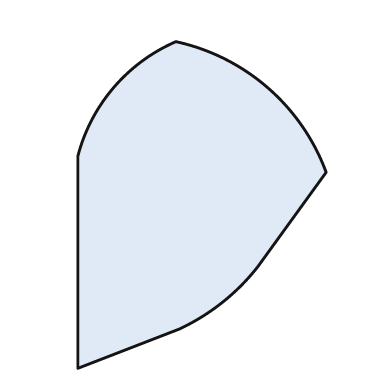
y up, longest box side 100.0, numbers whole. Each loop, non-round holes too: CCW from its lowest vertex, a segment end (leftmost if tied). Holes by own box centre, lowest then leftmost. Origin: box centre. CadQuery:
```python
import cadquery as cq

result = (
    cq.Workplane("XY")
    .moveTo(-38.0, -50.0)
    .lineTo(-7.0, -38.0)
    .threePointArc((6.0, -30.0), (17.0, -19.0))
    .lineTo(38.0, 10.0)
    .threePointArc((20.0, 36.0), (-8.0, 50.0))
    .threePointArc((-27.0, 36.0), (-38.0, 15.0))
    .close()
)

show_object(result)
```